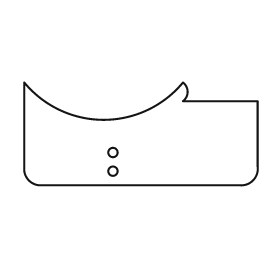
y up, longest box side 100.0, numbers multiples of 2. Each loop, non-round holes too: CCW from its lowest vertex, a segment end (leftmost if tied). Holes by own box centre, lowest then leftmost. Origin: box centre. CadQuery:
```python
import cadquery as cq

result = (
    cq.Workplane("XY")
    .moveTo(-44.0, -22.0)
    .lineTo(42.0, -22.0)
    .threePointArc((48.0, -20.0), (50.0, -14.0))
    .lineTo(50.0, 14.0)
    .lineTo(18.0, 14.0)
    .threePointArc((20.0, 18.0), (18.0, 22.0))
    .threePointArc((-16.0, 6.0), (-50.0, 22.0))
    .lineTo(-50.0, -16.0)
    .threePointArc((-48.0, -20.0), (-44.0, -22.0))
    .close()
    .moveTo(-12.0, -16.0)
    .circle(2.0)
    .moveTo(-12.0, -8.0)
    .circle(2.0)
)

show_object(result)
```